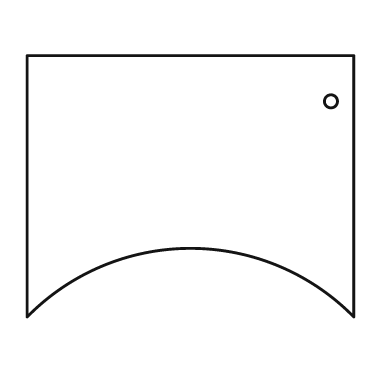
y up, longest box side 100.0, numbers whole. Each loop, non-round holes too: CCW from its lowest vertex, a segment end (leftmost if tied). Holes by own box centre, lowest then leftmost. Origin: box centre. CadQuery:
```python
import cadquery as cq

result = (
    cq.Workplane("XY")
    .moveTo(-50.0, -40.0)
    .threePointArc((0.0, -19.0), (50.0, -40.0))
    .lineTo(50.0, 40.0)
    .lineTo(-50.0, 40.0)
    .close()
    .moveTo(43.0, 26.0)
    .circle(2.0)
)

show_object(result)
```